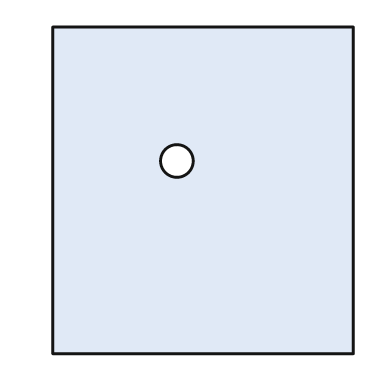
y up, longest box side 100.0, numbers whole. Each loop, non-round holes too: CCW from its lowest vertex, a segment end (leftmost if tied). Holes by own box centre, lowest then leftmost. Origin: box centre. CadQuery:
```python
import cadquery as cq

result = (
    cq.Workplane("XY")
    .moveTo(-46.0, -50.0)
    .lineTo(46.0, -50.0)
    .lineTo(46.0, 50.0)
    .lineTo(-46.0, 50.0)
    .close()
    .moveTo(-8.0, 9.0)
    .circle(5.0)
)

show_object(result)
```